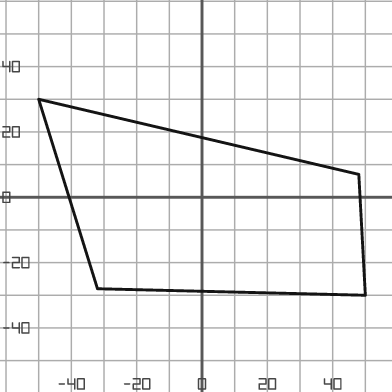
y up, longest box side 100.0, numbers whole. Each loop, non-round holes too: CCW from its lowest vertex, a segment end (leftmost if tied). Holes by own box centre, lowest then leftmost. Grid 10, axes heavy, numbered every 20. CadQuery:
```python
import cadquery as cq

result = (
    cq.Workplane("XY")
    .moveTo(50.0, -30.0)
    .lineTo(48.0, 7.0)
    .lineTo(-50.0, 30.0)
    .lineTo(-32.0, -28.0)
    .close()
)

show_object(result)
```